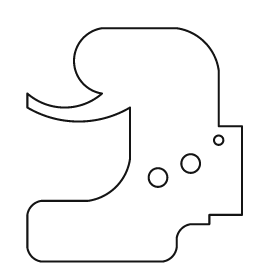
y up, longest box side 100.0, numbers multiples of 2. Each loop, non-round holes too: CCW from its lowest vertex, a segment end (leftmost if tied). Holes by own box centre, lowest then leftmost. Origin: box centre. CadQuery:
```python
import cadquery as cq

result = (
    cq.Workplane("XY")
    .moveTo(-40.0, -50.0)
    .lineTo(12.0, -50.0)
    .threePointArc((16.0, -48.0), (18.0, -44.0))
    .lineTo(18.0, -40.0)
    .threePointArc((20.0, -36.0), (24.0, -34.0))
    .lineTo(32.0, -34.0)
    .lineTo(32.0, -30.0)
    .lineTo(46.0, -30.0)
    .lineTo(46.0, 8.0)
    .lineTo(36.0, 8.0)
    .lineTo(36.0, 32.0)
    .threePointArc((30.0, 44.0), (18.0, 50.0))
    .lineTo(-14.0, 50.0)
    .threePointArc((-26.0, 36.0), (-14.0, 22.0))
    .threePointArc((-30.0, 16.0), (-46.0, 22.0))
    .lineTo(-46.0, 16.0)
    .threePointArc((-24.0, 10.0), (-2.0, 16.0))
    .lineTo(-2.0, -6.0)
    .threePointArc((-8.0, -18.0), (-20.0, -24.0))
    .lineTo(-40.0, -24.0)
    .threePointArc((-44.0, -26.0), (-46.0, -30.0))
    .lineTo(-46.0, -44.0)
    .threePointArc((-44.0, -48.0), (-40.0, -50.0))
    .close()
    .moveTo(10.0, -14.0)
    .circle(4.0)
    .moveTo(24.0, -8.0)
    .circle(4.0)
    .moveTo(36.0, 2.0)
    .circle(2.0)
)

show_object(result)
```